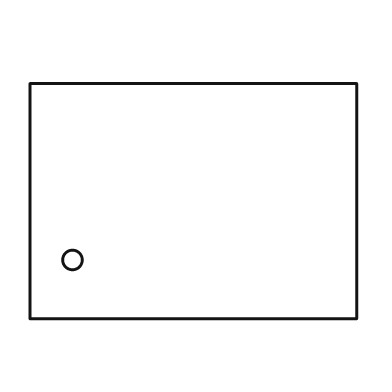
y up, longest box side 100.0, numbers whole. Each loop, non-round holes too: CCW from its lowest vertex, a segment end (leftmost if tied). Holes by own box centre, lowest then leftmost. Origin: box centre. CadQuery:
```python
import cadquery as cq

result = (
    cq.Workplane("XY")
    .moveTo(-50.0, -36.0)
    .lineTo(50.0, -36.0)
    .lineTo(50.0, 36.0)
    .lineTo(-50.0, 36.0)
    .close()
    .moveTo(-37.0, -18.0)
    .circle(3.0)
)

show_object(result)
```